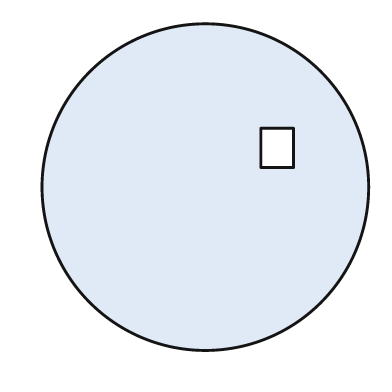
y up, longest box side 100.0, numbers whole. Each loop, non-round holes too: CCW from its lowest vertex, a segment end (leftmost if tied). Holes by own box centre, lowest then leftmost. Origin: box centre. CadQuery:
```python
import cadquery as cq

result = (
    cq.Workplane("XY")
    .moveTo(0.0, 0.0)
    .circle(50.0)
    .moveTo(17.0, 6.0)
    .lineTo(27.0, 6.0)
    .lineTo(27.0, 18.0)
    .lineTo(17.0, 18.0)
    .close()
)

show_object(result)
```